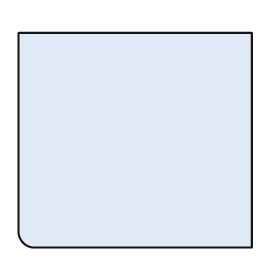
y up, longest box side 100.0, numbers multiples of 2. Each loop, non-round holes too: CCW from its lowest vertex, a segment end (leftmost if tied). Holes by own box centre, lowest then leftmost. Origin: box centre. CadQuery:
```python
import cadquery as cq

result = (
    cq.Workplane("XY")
    .moveTo(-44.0, -46.0)
    .lineTo(50.0, -46.0)
    .lineTo(50.0, 46.0)
    .lineTo(-50.0, 46.0)
    .lineTo(-50.0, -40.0)
    .threePointArc((-48.0, -44.0), (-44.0, -46.0))
    .close()
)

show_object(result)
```